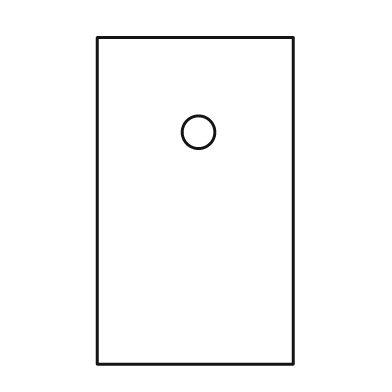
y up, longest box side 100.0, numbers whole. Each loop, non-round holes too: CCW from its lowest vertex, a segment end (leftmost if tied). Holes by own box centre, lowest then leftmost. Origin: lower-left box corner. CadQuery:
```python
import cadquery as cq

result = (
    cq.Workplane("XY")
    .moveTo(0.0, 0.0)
    .lineTo(60.0, 0.0)
    .lineTo(60.0, 100.0)
    .lineTo(0.0, 100.0)
    .close()
    .moveTo(31.0, 71.0)
    .circle(5.0)
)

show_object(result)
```